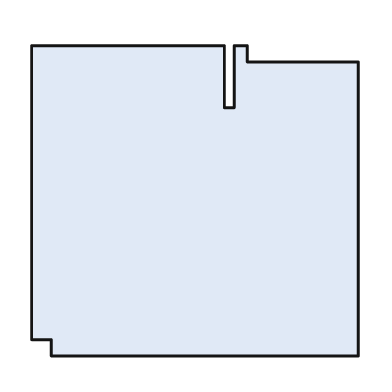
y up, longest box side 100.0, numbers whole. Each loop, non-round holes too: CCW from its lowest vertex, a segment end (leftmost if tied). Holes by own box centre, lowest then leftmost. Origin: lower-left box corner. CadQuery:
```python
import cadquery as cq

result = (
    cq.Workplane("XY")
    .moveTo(6.0, 0.0)
    .lineTo(100.0, 0.0)
    .lineTo(100.0, 90.0)
    .lineTo(66.0, 90.0)
    .lineTo(66.0, 95.0)
    .lineTo(62.0, 95.0)
    .lineTo(62.0, 76.0)
    .lineTo(59.0, 76.0)
    .lineTo(59.0, 95.0)
    .lineTo(0.0, 95.0)
    .lineTo(0.0, 5.0)
    .lineTo(6.0, 5.0)
    .close()
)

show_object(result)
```